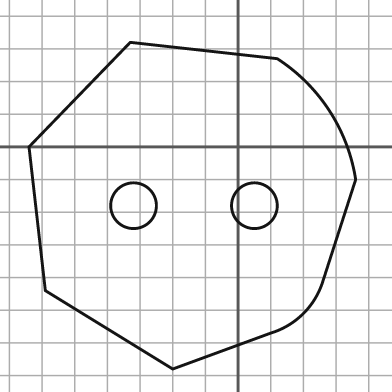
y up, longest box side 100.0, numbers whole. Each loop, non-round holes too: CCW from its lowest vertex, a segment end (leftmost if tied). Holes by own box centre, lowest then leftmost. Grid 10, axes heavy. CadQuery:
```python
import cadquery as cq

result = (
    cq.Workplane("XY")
    .moveTo(-20.0, -68.0)
    .lineTo(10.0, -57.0)
    .threePointArc((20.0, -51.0), (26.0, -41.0))
    .lineTo(36.0, -10.0)
    .threePointArc((28.0, 11.0), (12.0, 27.0))
    .lineTo(-33.0, 32.0)
    .lineTo(-64.0, 0.0)
    .lineTo(-59.0, -44.0)
    .close()
    .moveTo(-32.0, -18.0)
    .circle(7.0)
    .moveTo(5.0, -18.0)
    .circle(7.0)
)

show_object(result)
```